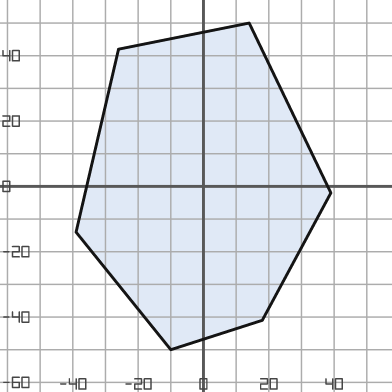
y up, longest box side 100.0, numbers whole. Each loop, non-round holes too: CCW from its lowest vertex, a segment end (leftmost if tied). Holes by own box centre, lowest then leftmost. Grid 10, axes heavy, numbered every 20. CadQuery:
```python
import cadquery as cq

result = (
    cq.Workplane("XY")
    .moveTo(-10.0, -50.0)
    .lineTo(18.0, -41.0)
    .lineTo(39.0, -2.0)
    .lineTo(14.0, 50.0)
    .lineTo(-26.0, 42.0)
    .lineTo(-39.0, -14.0)
    .close()
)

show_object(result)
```